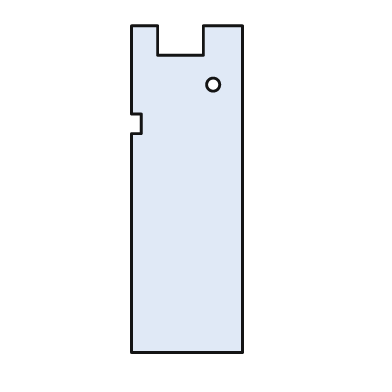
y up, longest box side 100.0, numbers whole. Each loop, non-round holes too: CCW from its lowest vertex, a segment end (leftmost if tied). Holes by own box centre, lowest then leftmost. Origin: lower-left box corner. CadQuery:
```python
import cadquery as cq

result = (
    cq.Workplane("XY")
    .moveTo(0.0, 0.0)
    .lineTo(34.0, 0.0)
    .lineTo(34.0, 100.0)
    .lineTo(22.0, 100.0)
    .lineTo(22.0, 91.0)
    .lineTo(8.0, 91.0)
    .lineTo(8.0, 100.0)
    .lineTo(0.0, 100.0)
    .lineTo(0.0, 73.0)
    .lineTo(3.0, 73.0)
    .lineTo(3.0, 67.0)
    .lineTo(0.0, 67.0)
    .close()
    .moveTo(25.0, 82.0)
    .circle(2.0)
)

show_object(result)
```